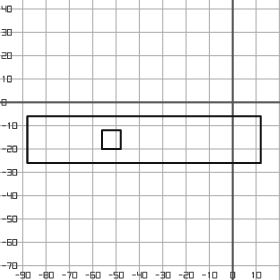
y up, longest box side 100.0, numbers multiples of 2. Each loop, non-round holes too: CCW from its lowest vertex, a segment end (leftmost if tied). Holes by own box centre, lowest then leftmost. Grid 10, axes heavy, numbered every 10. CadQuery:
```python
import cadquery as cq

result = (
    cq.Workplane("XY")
    .moveTo(-88.0, -26.0)
    .lineTo(12.0, -26.0)
    .lineTo(12.0, -6.0)
    .lineTo(-88.0, -6.0)
    .close()
    .moveTo(-56.0, -20.0)
    .lineTo(-48.0, -20.0)
    .lineTo(-48.0, -12.0)
    .lineTo(-56.0, -12.0)
    .close()
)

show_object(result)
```